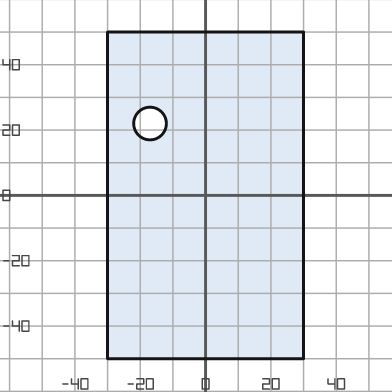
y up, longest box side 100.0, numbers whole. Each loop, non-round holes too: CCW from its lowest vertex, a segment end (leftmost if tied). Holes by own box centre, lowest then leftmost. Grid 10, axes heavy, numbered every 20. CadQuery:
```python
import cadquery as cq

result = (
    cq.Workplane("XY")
    .moveTo(-30.0, -50.0)
    .lineTo(30.0, -50.0)
    .lineTo(30.0, 50.0)
    .lineTo(-30.0, 50.0)
    .close()
    .moveTo(-17.0, 22.0)
    .circle(5.0)
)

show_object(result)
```